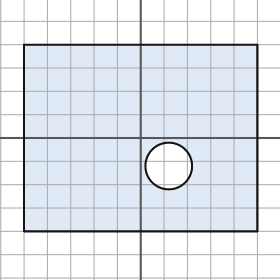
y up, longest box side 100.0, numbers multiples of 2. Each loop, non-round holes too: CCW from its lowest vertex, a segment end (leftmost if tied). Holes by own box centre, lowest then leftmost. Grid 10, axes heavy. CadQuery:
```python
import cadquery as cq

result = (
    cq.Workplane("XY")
    .moveTo(-50.0, -40.0)
    .lineTo(50.0, -40.0)
    .lineTo(50.0, 40.0)
    .lineTo(-50.0, 40.0)
    .close()
    .moveTo(12.0, -12.0)
    .circle(10.0)
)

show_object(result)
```